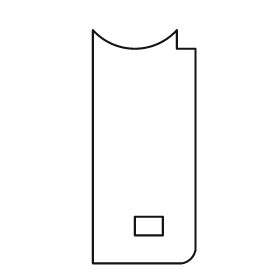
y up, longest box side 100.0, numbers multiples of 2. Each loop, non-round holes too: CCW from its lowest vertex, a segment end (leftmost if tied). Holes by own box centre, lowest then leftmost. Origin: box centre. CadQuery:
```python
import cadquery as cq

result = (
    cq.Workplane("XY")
    .moveTo(-22.0, -50.0)
    .lineTo(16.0, -50.0)
    .threePointArc((20.0, -48.0), (22.0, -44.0))
    .lineTo(22.0, 42.0)
    .lineTo(14.0, 42.0)
    .lineTo(14.0, 50.0)
    .threePointArc((-4.0, 42.0), (-22.0, 50.0))
    .close()
    .moveTo(-4.0, -38.0)
    .lineTo(8.0, -38.0)
    .lineTo(8.0, -30.0)
    .lineTo(-4.0, -30.0)
    .close()
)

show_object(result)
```